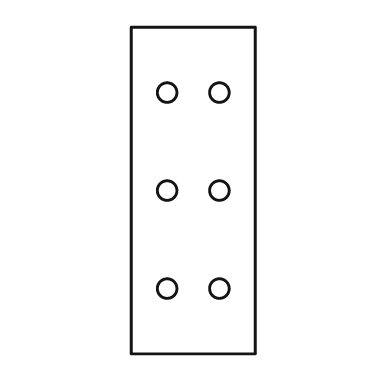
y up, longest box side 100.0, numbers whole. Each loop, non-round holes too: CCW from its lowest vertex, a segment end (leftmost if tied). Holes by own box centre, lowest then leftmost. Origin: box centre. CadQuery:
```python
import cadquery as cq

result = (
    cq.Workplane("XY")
    .moveTo(-19.0, -50.0)
    .lineTo(19.0, -50.0)
    .lineTo(19.0, 50.0)
    .lineTo(-19.0, 50.0)
    .close()
    .moveTo(-8.0, -30.0)
    .circle(3.0)
    .moveTo(8.0, -30.0)
    .circle(3.0)
    .moveTo(-8.0, 0.0)
    .circle(3.0)
    .moveTo(8.0, 0.0)
    .circle(3.0)
    .moveTo(-8.0, 30.0)
    .circle(3.0)
    .moveTo(8.0, 30.0)
    .circle(3.0)
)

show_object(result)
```